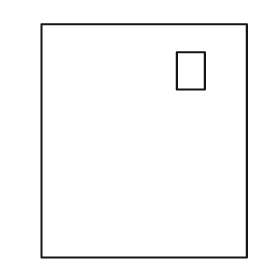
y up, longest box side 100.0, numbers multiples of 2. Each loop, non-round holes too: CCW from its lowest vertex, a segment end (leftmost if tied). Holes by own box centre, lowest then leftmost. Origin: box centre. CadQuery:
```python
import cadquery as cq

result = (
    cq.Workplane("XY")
    .moveTo(-44.0, -50.0)
    .lineTo(44.0, -50.0)
    .lineTo(44.0, 50.0)
    .lineTo(-44.0, 50.0)
    .close()
    .moveTo(14.0, 22.0)
    .lineTo(26.0, 22.0)
    .lineTo(26.0, 38.0)
    .lineTo(14.0, 38.0)
    .close()
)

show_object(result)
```